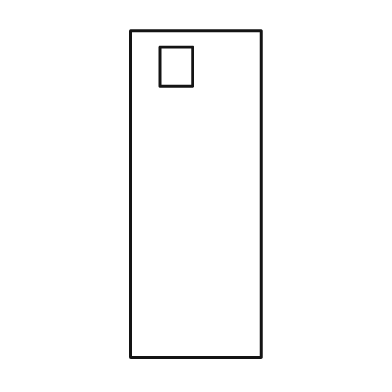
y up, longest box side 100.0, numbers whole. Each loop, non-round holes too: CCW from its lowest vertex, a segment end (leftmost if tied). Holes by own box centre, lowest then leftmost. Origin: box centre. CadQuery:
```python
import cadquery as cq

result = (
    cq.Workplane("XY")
    .moveTo(-20.0, -50.0)
    .lineTo(20.0, -50.0)
    .lineTo(20.0, 50.0)
    .lineTo(-20.0, 50.0)
    .close()
    .moveTo(-11.0, 33.0)
    .lineTo(-1.0, 33.0)
    .lineTo(-1.0, 45.0)
    .lineTo(-11.0, 45.0)
    .close()
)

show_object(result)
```